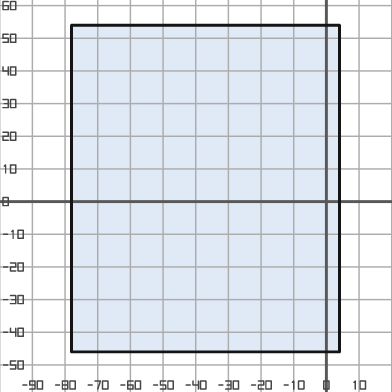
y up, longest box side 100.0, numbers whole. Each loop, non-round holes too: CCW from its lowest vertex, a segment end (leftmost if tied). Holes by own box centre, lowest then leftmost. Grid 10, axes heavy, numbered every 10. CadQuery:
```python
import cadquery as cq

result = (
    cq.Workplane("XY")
    .moveTo(-78.0, -46.0)
    .lineTo(4.0, -46.0)
    .lineTo(4.0, 54.0)
    .lineTo(-78.0, 54.0)
    .close()
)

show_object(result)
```